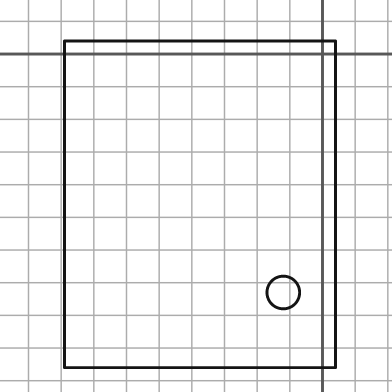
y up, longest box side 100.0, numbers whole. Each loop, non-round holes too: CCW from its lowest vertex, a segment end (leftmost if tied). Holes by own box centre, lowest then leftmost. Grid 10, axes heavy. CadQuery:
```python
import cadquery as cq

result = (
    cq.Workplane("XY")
    .moveTo(-79.0, -96.0)
    .lineTo(4.0, -96.0)
    .lineTo(4.0, 4.0)
    .lineTo(-79.0, 4.0)
    .close()
    .moveTo(-12.0, -73.0)
    .circle(5.0)
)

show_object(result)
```